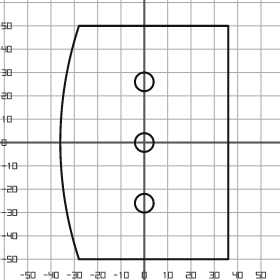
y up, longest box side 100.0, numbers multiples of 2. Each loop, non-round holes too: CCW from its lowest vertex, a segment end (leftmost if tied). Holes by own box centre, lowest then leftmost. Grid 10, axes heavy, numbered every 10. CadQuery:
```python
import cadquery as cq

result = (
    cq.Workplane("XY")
    .moveTo(-28.0, -50.0)
    .lineTo(36.0, -50.0)
    .lineTo(36.0, 50.0)
    .lineTo(-28.0, 50.0)
    .threePointArc((-36.0, 0.0), (-28.0, -50.0))
    .close()
    .moveTo(0.0, -26.0)
    .circle(4.0)
    .moveTo(0.0, 0.0)
    .circle(4.0)
    .moveTo(0.0, 26.0)
    .circle(4.0)
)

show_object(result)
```